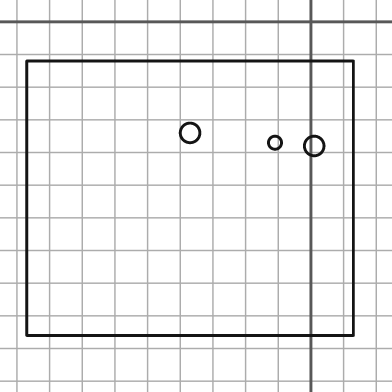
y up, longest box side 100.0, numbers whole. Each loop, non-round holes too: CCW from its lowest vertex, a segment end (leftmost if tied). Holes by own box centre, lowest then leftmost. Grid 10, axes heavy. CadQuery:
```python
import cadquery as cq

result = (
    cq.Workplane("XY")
    .moveTo(-87.0, -96.0)
    .lineTo(13.0, -96.0)
    .lineTo(13.0, -12.0)
    .lineTo(-87.0, -12.0)
    .close()
    .moveTo(1.0, -38.0)
    .circle(3.0)
    .moveTo(-11.0, -37.0)
    .circle(2.0)
    .moveTo(-37.0, -34.0)
    .circle(3.0)
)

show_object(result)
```